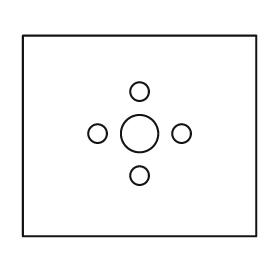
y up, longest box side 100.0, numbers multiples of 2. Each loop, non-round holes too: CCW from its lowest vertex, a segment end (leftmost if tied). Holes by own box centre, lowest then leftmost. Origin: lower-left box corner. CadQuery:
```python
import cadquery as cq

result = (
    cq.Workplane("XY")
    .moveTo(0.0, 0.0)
    .lineTo(100.0, 0.0)
    .lineTo(100.0, 86.0)
    .lineTo(0.0, 86.0)
    .close()
    .moveTo(50.0, 26.0)
    .circle(4.0)
    .moveTo(32.0, 44.0)
    .circle(4.0)
    .moveTo(50.0, 44.0)
    .circle(8.0)
    .moveTo(68.0, 44.0)
    .circle(4.0)
    .moveTo(50.0, 62.0)
    .circle(4.0)
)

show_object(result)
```